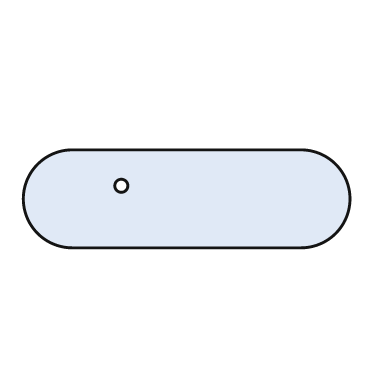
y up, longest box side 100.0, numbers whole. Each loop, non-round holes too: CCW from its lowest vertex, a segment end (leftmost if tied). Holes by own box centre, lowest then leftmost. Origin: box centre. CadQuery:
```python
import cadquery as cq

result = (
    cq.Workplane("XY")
    .moveTo(-35.0, -15.0)
    .lineTo(35.0, -15.0)
    .threePointArc((50.0, 0.0), (35.0, 15.0))
    .lineTo(-35.0, 15.0)
    .threePointArc((-50.0, 0.0), (-35.0, -15.0))
    .close()
    .moveTo(-20.0, 4.0)
    .circle(2.0)
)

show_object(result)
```